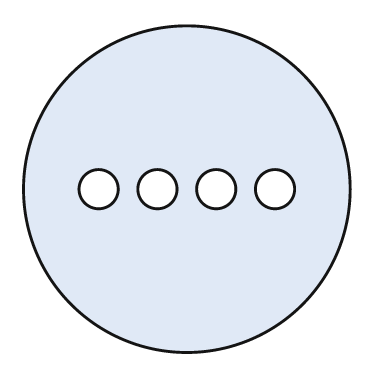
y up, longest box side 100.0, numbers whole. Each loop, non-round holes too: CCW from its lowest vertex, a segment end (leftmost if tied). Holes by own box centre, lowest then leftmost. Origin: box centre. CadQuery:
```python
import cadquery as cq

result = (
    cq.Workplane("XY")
    .moveTo(0.0, 0.0)
    .circle(50.0)
    .moveTo(-27.0, 0.0)
    .circle(6.0)
    .moveTo(-9.0, 0.0)
    .circle(6.0)
    .moveTo(9.0, 0.0)
    .circle(6.0)
    .moveTo(27.0, 0.0)
    .circle(6.0)
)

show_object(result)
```